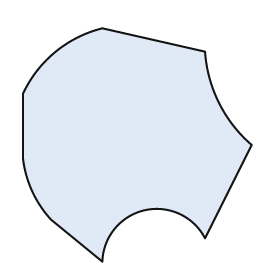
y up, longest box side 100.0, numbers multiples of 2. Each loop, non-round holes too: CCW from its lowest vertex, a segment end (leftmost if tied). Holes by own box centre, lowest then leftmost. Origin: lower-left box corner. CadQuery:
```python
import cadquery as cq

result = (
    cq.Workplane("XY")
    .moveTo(34.0, 0.0)
    .threePointArc((52.0, 22.0), (78.0, 10.0))
    .lineTo(98.0, 50.0)
    .threePointArc((84.0, 68.0), (78.0, 90.0))
    .lineTo(34.0, 100.0)
    .threePointArc((14.0, 90.0), (0.0, 72.0))
    .lineTo(0.0, 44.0)
    .threePointArc((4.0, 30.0), (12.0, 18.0))
    .close()
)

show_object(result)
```